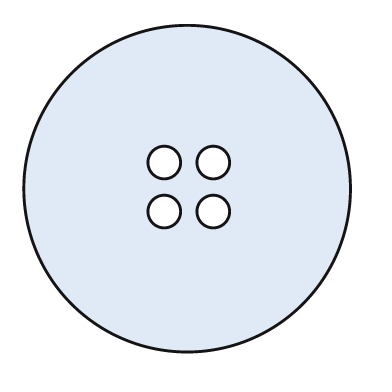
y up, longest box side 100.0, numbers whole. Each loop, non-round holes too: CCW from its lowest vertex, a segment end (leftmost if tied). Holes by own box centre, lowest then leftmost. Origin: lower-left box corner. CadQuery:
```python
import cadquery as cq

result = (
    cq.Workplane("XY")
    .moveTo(50.0, 50.0)
    .circle(50.0)
    .moveTo(43.0, 43.0)
    .circle(5.0)
    .moveTo(58.0, 43.0)
    .circle(5.0)
    .moveTo(43.0, 58.0)
    .circle(5.0)
    .moveTo(58.0, 58.0)
    .circle(5.0)
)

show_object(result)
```